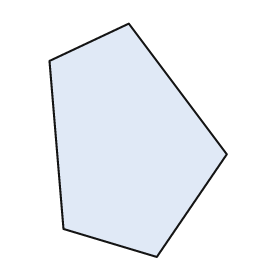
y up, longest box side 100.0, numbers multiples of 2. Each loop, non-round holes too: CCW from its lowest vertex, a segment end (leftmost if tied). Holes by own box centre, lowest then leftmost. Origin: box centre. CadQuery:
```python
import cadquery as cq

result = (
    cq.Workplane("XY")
    .moveTo(8.0, -50.0)
    .lineTo(38.0, -6.0)
    .lineTo(-4.0, 50.0)
    .lineTo(-38.0, 34.0)
    .lineTo(-32.0, -38.0)
    .close()
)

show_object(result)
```